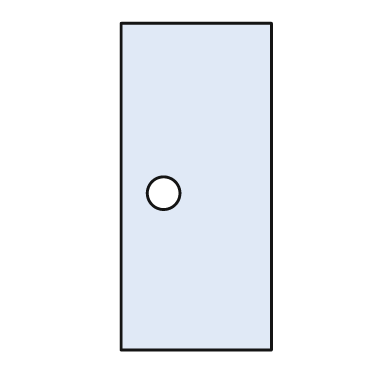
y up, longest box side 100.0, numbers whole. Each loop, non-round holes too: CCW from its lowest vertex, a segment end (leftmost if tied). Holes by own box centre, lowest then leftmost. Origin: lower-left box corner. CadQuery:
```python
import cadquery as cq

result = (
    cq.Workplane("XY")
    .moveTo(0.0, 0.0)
    .lineTo(46.0, 0.0)
    .lineTo(46.0, 100.0)
    .lineTo(0.0, 100.0)
    .close()
    .moveTo(13.0, 48.0)
    .circle(5.0)
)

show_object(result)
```